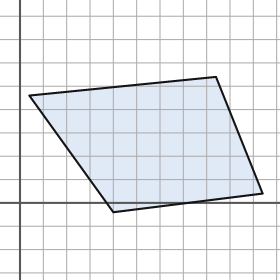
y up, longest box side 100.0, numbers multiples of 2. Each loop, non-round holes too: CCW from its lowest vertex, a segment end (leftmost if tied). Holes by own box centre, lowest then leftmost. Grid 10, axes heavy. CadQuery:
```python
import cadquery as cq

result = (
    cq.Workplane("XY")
    .moveTo(40.0, -4.0)
    .lineTo(104.0, 4.0)
    .lineTo(84.0, 54.0)
    .lineTo(4.0, 46.0)
    .close()
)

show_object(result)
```